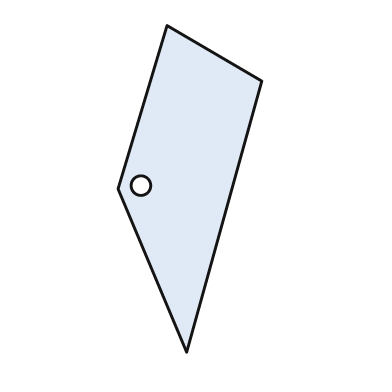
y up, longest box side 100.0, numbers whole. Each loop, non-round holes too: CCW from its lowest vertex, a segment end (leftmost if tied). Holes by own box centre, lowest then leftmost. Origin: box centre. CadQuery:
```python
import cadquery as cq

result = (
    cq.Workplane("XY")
    .moveTo(-1.0, -50.0)
    .lineTo(22.0, 33.0)
    .lineTo(-7.0, 50.0)
    .lineTo(-22.0, 0.0)
    .close()
    .moveTo(-15.0, 1.0)
    .circle(3.0)
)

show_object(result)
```